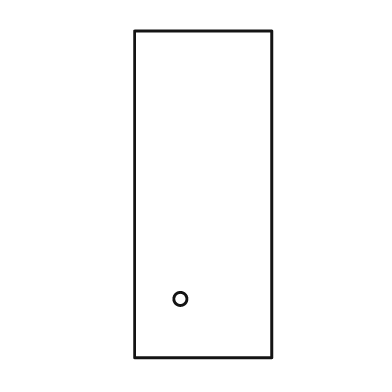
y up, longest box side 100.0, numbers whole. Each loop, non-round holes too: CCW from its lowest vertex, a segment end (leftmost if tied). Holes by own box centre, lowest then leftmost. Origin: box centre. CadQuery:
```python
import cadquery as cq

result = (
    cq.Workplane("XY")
    .moveTo(-21.0, -50.0)
    .lineTo(21.0, -50.0)
    .lineTo(21.0, 50.0)
    .lineTo(-21.0, 50.0)
    .close()
    .moveTo(-7.0, -32.0)
    .circle(2.0)
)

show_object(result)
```